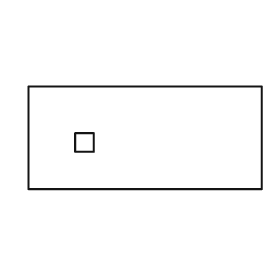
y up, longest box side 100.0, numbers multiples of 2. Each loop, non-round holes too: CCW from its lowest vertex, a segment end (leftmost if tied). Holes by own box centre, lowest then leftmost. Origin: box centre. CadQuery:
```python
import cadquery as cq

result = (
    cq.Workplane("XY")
    .moveTo(-50.0, -22.0)
    .lineTo(50.0, -22.0)
    .lineTo(50.0, 22.0)
    .lineTo(-50.0, 22.0)
    .close()
    .moveTo(-30.0, -6.0)
    .lineTo(-22.0, -6.0)
    .lineTo(-22.0, 2.0)
    .lineTo(-30.0, 2.0)
    .close()
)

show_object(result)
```